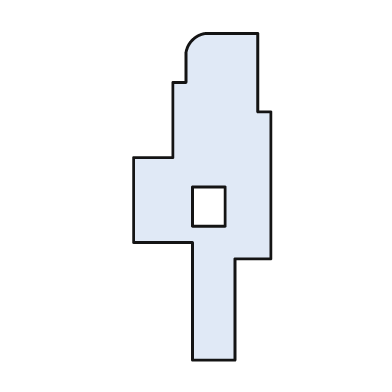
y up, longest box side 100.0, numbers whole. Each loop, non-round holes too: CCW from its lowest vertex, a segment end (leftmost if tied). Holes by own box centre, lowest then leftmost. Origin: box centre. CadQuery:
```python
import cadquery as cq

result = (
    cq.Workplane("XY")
    .moveTo(-3.0, -50.0)
    .lineTo(10.0, -50.0)
    .lineTo(10.0, -19.0)
    .lineTo(21.0, -19.0)
    .lineTo(21.0, 26.0)
    .lineTo(17.0, 26.0)
    .lineTo(17.0, 50.0)
    .lineTo(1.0, 50.0)
    .threePointArc((-3.0, 48.0), (-5.0, 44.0))
    .lineTo(-5.0, 35.0)
    .lineTo(-9.0, 35.0)
    .lineTo(-9.0, 12.0)
    .lineTo(-21.0, 12.0)
    .lineTo(-21.0, -14.0)
    .lineTo(-3.0, -14.0)
    .close()
    .moveTo(-3.0, -9.0)
    .lineTo(7.0, -9.0)
    .lineTo(7.0, 3.0)
    .lineTo(-3.0, 3.0)
    .close()
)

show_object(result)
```